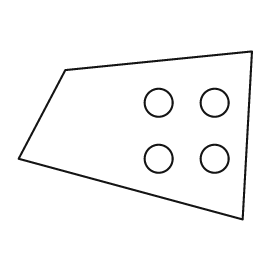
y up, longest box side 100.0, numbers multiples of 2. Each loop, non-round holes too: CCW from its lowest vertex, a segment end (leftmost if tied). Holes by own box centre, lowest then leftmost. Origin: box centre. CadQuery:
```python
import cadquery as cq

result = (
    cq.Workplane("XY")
    .moveTo(46.0, -36.0)
    .lineTo(50.0, 36.0)
    .lineTo(-30.0, 28.0)
    .lineTo(-50.0, -10.0)
    .close()
    .moveTo(10.0, -10.0)
    .circle(6.0)
    .moveTo(34.0, -10.0)
    .circle(6.0)
    .moveTo(10.0, 14.0)
    .circle(6.0)
    .moveTo(34.0, 14.0)
    .circle(6.0)
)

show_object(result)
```